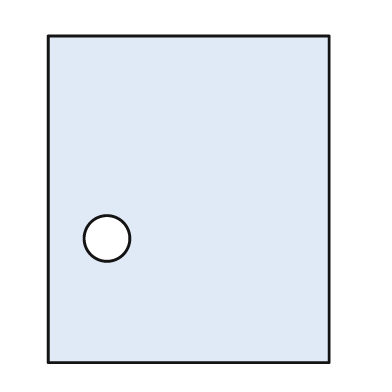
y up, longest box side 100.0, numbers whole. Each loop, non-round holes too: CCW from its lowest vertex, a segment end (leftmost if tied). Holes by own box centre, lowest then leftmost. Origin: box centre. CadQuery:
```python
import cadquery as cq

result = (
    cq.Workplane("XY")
    .moveTo(-43.0, -50.0)
    .lineTo(43.0, -50.0)
    .lineTo(43.0, 50.0)
    .lineTo(-43.0, 50.0)
    .close()
    .moveTo(-25.0, -12.0)
    .circle(7.0)
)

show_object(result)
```